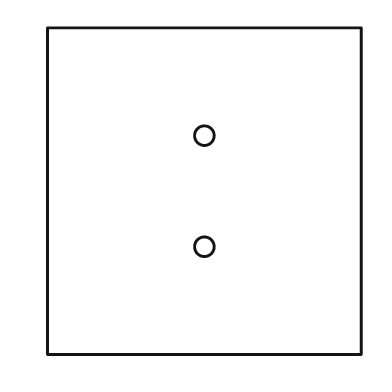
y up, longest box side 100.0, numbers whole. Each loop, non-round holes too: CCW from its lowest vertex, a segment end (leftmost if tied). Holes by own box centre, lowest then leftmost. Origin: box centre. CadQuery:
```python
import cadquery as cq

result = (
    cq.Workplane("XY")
    .moveTo(-48.0, -50.0)
    .lineTo(48.0, -50.0)
    .lineTo(48.0, 50.0)
    .lineTo(-48.0, 50.0)
    .close()
    .moveTo(0.0, -17.0)
    .circle(3.0)
    .moveTo(0.0, 17.0)
    .circle(3.0)
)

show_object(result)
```